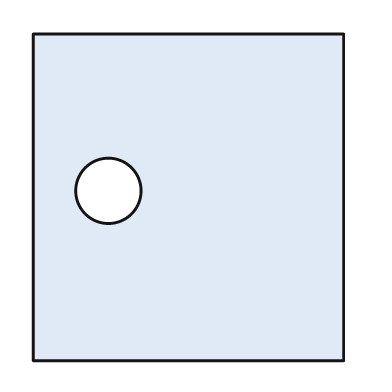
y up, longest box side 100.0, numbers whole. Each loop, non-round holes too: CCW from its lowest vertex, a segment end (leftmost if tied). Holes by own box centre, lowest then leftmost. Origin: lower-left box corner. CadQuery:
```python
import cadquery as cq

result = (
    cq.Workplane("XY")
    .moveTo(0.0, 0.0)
    .lineTo(95.0, 0.0)
    .lineTo(95.0, 100.0)
    .lineTo(0.0, 100.0)
    .close()
    .moveTo(23.0, 52.0)
    .circle(10.0)
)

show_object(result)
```